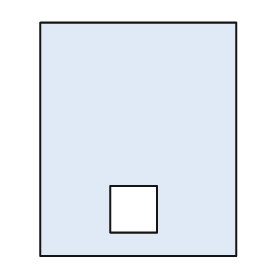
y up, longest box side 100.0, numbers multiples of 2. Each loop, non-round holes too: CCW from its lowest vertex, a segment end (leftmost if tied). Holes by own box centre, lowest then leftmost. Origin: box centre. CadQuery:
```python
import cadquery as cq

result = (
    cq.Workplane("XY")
    .moveTo(-42.0, -50.0)
    .lineTo(42.0, -50.0)
    .lineTo(42.0, 50.0)
    .lineTo(-42.0, 50.0)
    .close()
    .moveTo(-12.0, -40.0)
    .lineTo(8.0, -40.0)
    .lineTo(8.0, -20.0)
    .lineTo(-12.0, -20.0)
    .close()
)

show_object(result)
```